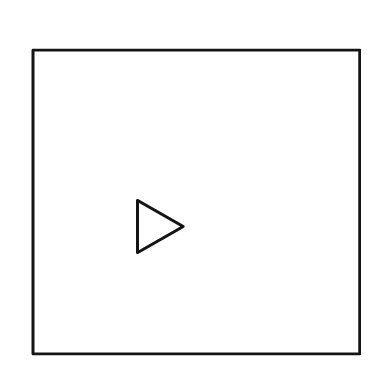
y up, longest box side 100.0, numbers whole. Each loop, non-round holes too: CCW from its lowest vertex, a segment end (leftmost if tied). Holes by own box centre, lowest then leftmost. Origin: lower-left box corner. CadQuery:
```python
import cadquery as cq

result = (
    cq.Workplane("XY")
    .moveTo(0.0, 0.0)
    .lineTo(100.0, 0.0)
    .lineTo(100.0, 93.0)
    .lineTo(0.0, 93.0)
    .close()
    .moveTo(32.0, 31.0)
    .lineTo(46.0, 39.0)
    .lineTo(32.0, 47.0)
    .close()
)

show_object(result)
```